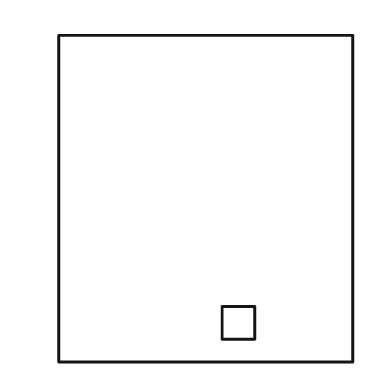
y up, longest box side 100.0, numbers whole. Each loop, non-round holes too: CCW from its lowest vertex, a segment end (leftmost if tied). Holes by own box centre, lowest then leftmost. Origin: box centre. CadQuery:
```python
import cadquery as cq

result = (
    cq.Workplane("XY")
    .moveTo(-45.0, -50.0)
    .lineTo(45.0, -50.0)
    .lineTo(45.0, 50.0)
    .lineTo(-45.0, 50.0)
    .close()
    .moveTo(5.0, -43.0)
    .lineTo(15.0, -43.0)
    .lineTo(15.0, -33.0)
    .lineTo(5.0, -33.0)
    .close()
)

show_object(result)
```